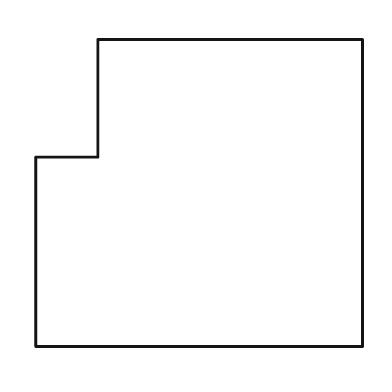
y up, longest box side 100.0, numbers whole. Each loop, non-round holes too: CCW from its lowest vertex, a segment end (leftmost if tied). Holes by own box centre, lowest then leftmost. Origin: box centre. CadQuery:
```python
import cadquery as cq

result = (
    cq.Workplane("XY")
    .moveTo(-50.0, -47.0)
    .lineTo(50.0, -47.0)
    .lineTo(50.0, 47.0)
    .lineTo(-31.0, 47.0)
    .lineTo(-31.0, 11.0)
    .lineTo(-50.0, 11.0)
    .close()
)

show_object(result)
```